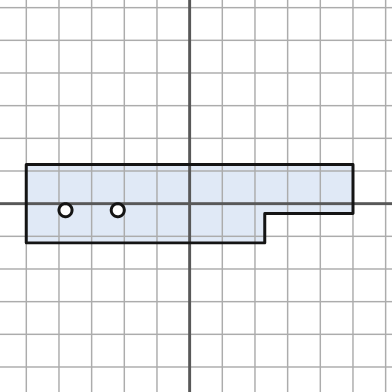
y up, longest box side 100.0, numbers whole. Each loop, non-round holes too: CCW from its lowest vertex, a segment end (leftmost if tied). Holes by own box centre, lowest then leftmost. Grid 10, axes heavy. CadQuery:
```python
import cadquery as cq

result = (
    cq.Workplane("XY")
    .moveTo(-50.0, -12.0)
    .lineTo(23.0, -12.0)
    .lineTo(23.0, -3.0)
    .lineTo(50.0, -3.0)
    .lineTo(50.0, 12.0)
    .lineTo(-50.0, 12.0)
    .close()
    .moveTo(-38.0, -2.0)
    .circle(2.0)
    .moveTo(-22.0, -2.0)
    .circle(2.0)
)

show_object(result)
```